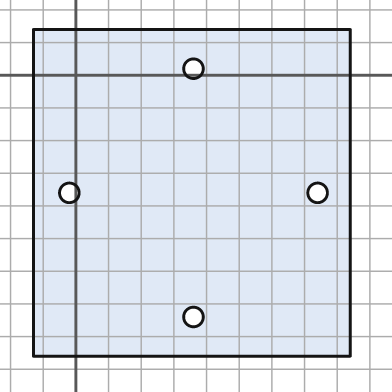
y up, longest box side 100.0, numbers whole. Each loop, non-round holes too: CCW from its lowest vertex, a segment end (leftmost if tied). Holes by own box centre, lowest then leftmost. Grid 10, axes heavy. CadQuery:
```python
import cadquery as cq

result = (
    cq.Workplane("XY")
    .moveTo(-13.0, -86.0)
    .lineTo(84.0, -86.0)
    .lineTo(84.0, 14.0)
    .lineTo(-13.0, 14.0)
    .close()
    .moveTo(36.0, -74.0)
    .circle(3.0)
    .moveTo(-2.0, -36.0)
    .circle(3.0)
    .moveTo(74.0, -36.0)
    .circle(3.0)
    .moveTo(36.0, 2.0)
    .circle(3.0)
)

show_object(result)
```